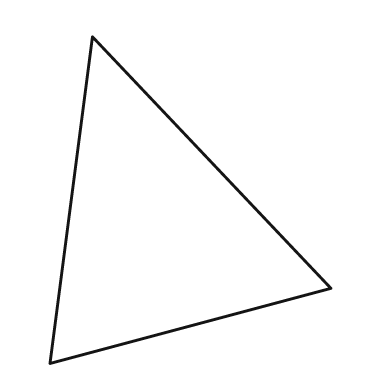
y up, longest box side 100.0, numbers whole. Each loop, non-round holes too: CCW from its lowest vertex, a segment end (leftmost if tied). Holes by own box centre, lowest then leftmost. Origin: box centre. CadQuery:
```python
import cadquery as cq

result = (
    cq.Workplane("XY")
    .moveTo(-43.0, -50.0)
    .lineTo(43.0, -27.0)
    .lineTo(-30.0, 50.0)
    .close()
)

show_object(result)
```